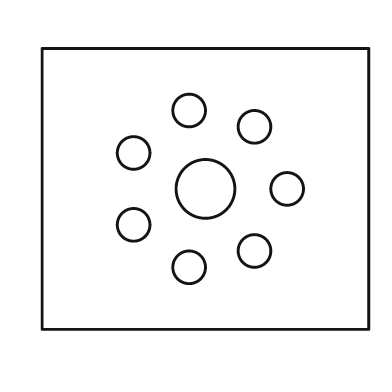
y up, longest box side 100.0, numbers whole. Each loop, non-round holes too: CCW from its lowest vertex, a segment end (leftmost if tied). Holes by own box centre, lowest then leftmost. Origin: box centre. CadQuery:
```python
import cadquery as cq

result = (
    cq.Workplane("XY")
    .moveTo(-50.0, -43.0)
    .lineTo(50.0, -43.0)
    .lineTo(50.0, 43.0)
    .lineTo(-50.0, 43.0)
    .close()
    .moveTo(-5.0, -24.0)
    .circle(5.0)
    .moveTo(15.0, -19.0)
    .circle(5.0)
    .moveTo(-22.0, -11.0)
    .circle(5.0)
    .moveTo(0.0, 0.0)
    .circle(9.0)
    .moveTo(25.0, 0.0)
    .circle(5.0)
    .moveTo(-22.0, 11.0)
    .circle(5.0)
    .moveTo(15.0, 19.0)
    .circle(5.0)
    .moveTo(-5.0, 24.0)
    .circle(5.0)
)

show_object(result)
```